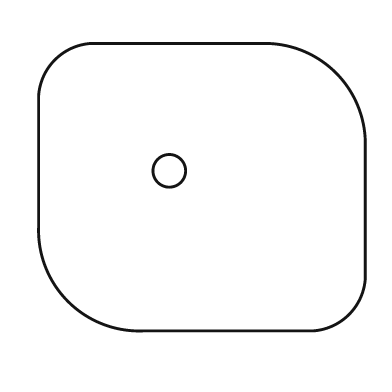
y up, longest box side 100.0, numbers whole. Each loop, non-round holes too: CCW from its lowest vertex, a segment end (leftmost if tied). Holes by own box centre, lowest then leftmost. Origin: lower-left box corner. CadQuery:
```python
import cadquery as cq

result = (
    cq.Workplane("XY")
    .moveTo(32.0, 0.0)
    .lineTo(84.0, 0.0)
    .threePointArc((95.0, 5.0), (100.0, 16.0))
    .lineTo(100.0, 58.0)
    .threePointArc((91.0, 79.0), (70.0, 88.0))
    .lineTo(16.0, 88.0)
    .threePointArc((5.0, 83.0), (0.0, 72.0))
    .lineTo(0.0, 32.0)
    .threePointArc((9.0, 9.0), (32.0, 0.0))
    .close()
    .moveTo(40.0, 49.0)
    .circle(5.0)
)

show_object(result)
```